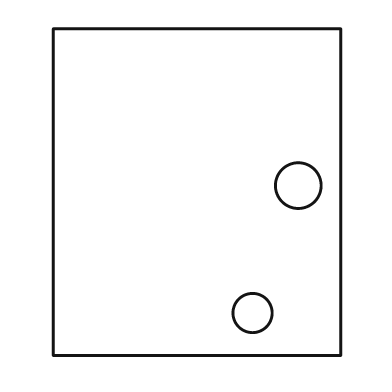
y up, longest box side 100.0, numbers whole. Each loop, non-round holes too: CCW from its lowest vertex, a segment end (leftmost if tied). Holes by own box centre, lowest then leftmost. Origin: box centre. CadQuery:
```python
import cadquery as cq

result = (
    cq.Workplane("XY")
    .moveTo(-44.0, -50.0)
    .lineTo(44.0, -50.0)
    .lineTo(44.0, 50.0)
    .lineTo(-44.0, 50.0)
    .close()
    .moveTo(17.0, -37.0)
    .circle(6.0)
    .moveTo(31.0, 2.0)
    .circle(7.0)
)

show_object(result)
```